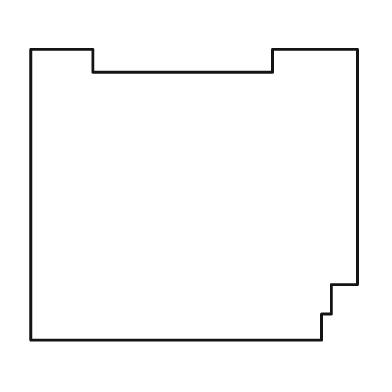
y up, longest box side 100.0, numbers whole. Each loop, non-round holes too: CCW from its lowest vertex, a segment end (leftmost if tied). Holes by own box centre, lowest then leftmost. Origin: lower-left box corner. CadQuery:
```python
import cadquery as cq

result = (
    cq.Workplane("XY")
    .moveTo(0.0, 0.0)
    .lineTo(89.0, 0.0)
    .lineTo(89.0, 8.0)
    .lineTo(92.0, 8.0)
    .lineTo(92.0, 17.0)
    .lineTo(100.0, 17.0)
    .lineTo(100.0, 89.0)
    .lineTo(74.0, 89.0)
    .lineTo(74.0, 82.0)
    .lineTo(19.0, 82.0)
    .lineTo(19.0, 89.0)
    .lineTo(0.0, 89.0)
    .close()
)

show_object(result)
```